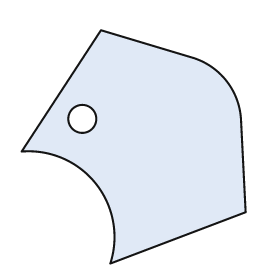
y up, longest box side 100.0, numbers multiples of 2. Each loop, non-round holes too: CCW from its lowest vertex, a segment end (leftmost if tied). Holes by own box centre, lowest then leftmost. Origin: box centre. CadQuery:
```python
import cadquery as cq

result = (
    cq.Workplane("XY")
    .moveTo(-10.0, -50.0)
    .lineTo(48.0, -28.0)
    .lineTo(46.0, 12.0)
    .threePointArc((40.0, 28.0), (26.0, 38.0))
    .lineTo(-14.0, 50.0)
    .lineTo(-48.0, -2.0)
    .threePointArc((-16.0, -16.0), (-10.0, -50.0))
    .close()
    .moveTo(-22.0, 12.0)
    .circle(6.0)
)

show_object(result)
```